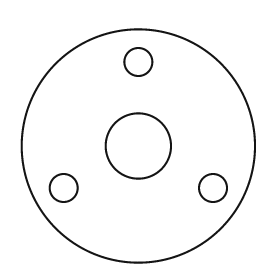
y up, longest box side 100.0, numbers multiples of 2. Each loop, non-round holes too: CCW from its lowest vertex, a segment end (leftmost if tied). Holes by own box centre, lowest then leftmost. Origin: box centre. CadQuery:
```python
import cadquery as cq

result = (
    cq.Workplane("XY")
    .moveTo(0.0, 0.0)
    .circle(50.0)
    .moveTo(-32.0, -18.0)
    .circle(6.0)
    .moveTo(32.0, -18.0)
    .circle(6.0)
    .moveTo(0.0, 0.0)
    .circle(14.0)
    .moveTo(0.0, 36.0)
    .circle(6.0)
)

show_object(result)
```